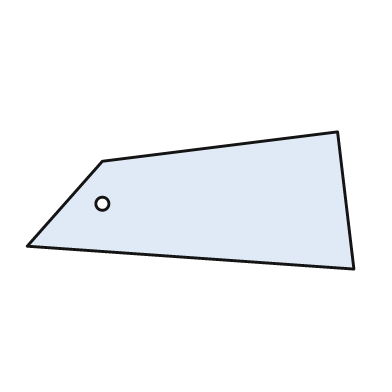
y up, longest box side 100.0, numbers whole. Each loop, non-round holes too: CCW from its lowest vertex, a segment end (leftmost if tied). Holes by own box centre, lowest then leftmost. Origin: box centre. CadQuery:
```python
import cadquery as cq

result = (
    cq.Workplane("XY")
    .moveTo(50.0, -21.0)
    .lineTo(45.0, 21.0)
    .lineTo(-27.0, 12.0)
    .lineTo(-50.0, -14.0)
    .close()
    .moveTo(-27.0, -1.0)
    .circle(2.0)
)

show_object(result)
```